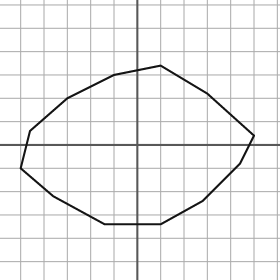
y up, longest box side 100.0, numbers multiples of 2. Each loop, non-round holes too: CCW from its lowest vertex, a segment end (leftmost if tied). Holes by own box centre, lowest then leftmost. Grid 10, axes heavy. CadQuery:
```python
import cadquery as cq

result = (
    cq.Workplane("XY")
    .moveTo(-14.0, -34.0)
    .lineTo(10.0, -34.0)
    .lineTo(28.0, -24.0)
    .lineTo(44.0, -8.0)
    .lineTo(50.0, 4.0)
    .lineTo(30.0, 22.0)
    .lineTo(10.0, 34.0)
    .lineTo(-10.0, 30.0)
    .lineTo(-30.0, 20.0)
    .lineTo(-46.0, 6.0)
    .lineTo(-50.0, -10.0)
    .lineTo(-36.0, -22.0)
    .close()
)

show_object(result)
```